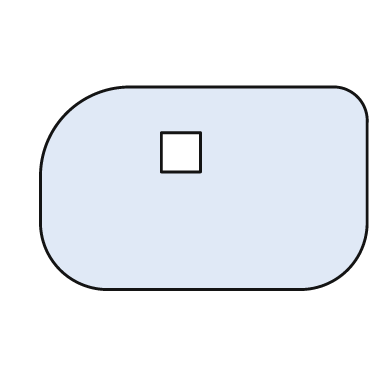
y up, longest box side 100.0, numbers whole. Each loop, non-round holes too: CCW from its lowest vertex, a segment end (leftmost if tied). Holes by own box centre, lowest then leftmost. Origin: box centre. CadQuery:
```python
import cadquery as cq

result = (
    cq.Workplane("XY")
    .moveTo(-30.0, -31.0)
    .lineTo(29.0, -31.0)
    .threePointArc((44.0, -25.0), (50.0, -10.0))
    .lineTo(50.0, 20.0)
    .threePointArc((47.0, 28.0), (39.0, 31.0))
    .lineTo(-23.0, 31.0)
    .threePointArc((-42.0, 23.0), (-50.0, 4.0))
    .lineTo(-50.0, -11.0)
    .threePointArc((-44.0, -25.0), (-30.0, -31.0))
    .close()
    .moveTo(-13.0, 5.0)
    .lineTo(-1.0, 5.0)
    .lineTo(-1.0, 17.0)
    .lineTo(-13.0, 17.0)
    .close()
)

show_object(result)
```